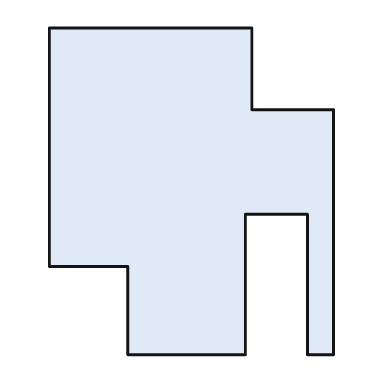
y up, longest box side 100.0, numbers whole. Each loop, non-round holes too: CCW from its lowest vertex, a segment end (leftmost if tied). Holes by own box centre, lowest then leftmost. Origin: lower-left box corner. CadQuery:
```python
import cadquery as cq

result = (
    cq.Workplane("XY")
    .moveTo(24.0, 0.0)
    .lineTo(60.0, 0.0)
    .lineTo(60.0, 43.0)
    .lineTo(79.0, 43.0)
    .lineTo(79.0, 0.0)
    .lineTo(87.0, 0.0)
    .lineTo(87.0, 75.0)
    .lineTo(62.0, 75.0)
    .lineTo(62.0, 100.0)
    .lineTo(0.0, 100.0)
    .lineTo(0.0, 27.0)
    .lineTo(24.0, 27.0)
    .close()
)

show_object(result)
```